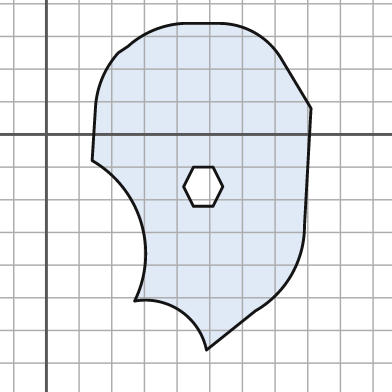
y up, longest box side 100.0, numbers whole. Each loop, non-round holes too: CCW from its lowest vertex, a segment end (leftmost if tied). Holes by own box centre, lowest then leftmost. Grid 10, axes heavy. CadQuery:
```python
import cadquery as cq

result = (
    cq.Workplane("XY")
    .moveTo(49.0, -66.0)
    .lineTo(64.0, -54.0)
    .threePointArc((75.0, -43.0), (79.0, -28.0))
    .lineTo(81.0, 8.0)
    .lineTo(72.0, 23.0)
    .threePointArc((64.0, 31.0), (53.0, 34.0))
    .lineTo(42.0, 34.0)
    .threePointArc((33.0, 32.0), (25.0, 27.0))
    .lineTo(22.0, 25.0)
    .threePointArc((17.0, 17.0), (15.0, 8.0))
    .lineTo(14.0, -8.0)
    .threePointArc((29.0, -27.0), (27.0, -51.0))
    .threePointArc((41.0, -54.0), (49.0, -66.0))
    .close()
    .moveTo(45.0, -22.0)
    .lineTo(51.0, -22.0)
    .lineTo(54.0, -16.0)
    .lineTo(51.0, -10.0)
    .lineTo(45.0, -10.0)
    .lineTo(42.0, -16.0)
    .close()
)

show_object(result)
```